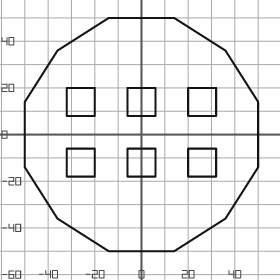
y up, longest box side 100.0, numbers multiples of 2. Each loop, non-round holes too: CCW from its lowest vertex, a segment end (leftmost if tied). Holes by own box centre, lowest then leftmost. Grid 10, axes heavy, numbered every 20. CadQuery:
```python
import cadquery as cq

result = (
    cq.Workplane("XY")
    .moveTo(-14.0, -50.0)
    .lineTo(14.0, -50.0)
    .lineTo(36.0, -36.0)
    .lineTo(50.0, -14.0)
    .lineTo(50.0, 14.0)
    .lineTo(36.0, 36.0)
    .lineTo(14.0, 50.0)
    .lineTo(-14.0, 50.0)
    .lineTo(-36.0, 36.0)
    .lineTo(-50.0, 14.0)
    .lineTo(-50.0, -14.0)
    .lineTo(-36.0, -36.0)
    .close()
    .moveTo(-32.0, -18.0)
    .lineTo(-20.0, -18.0)
    .lineTo(-20.0, -6.0)
    .lineTo(-32.0, -6.0)
    .close()
    .moveTo(-6.0, -18.0)
    .lineTo(6.0, -18.0)
    .lineTo(6.0, -6.0)
    .lineTo(-6.0, -6.0)
    .close()
    .moveTo(20.0, -18.0)
    .lineTo(32.0, -18.0)
    .lineTo(32.0, -6.0)
    .lineTo(20.0, -6.0)
    .close()
    .moveTo(-32.0, 8.0)
    .lineTo(-20.0, 8.0)
    .lineTo(-20.0, 20.0)
    .lineTo(-32.0, 20.0)
    .close()
    .moveTo(-6.0, 8.0)
    .lineTo(6.0, 8.0)
    .lineTo(6.0, 20.0)
    .lineTo(-6.0, 20.0)
    .close()
    .moveTo(20.0, 8.0)
    .lineTo(32.0, 8.0)
    .lineTo(32.0, 20.0)
    .lineTo(20.0, 20.0)
    .close()
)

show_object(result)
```